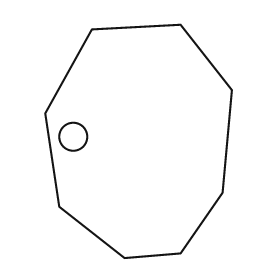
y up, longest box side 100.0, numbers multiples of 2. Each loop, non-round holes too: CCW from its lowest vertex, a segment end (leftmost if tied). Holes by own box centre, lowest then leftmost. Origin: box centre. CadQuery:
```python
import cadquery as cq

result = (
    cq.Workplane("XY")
    .moveTo(-6.0, -50.0)
    .lineTo(18.0, -48.0)
    .lineTo(36.0, -22.0)
    .lineTo(40.0, 22.0)
    .lineTo(18.0, 50.0)
    .lineTo(-20.0, 48.0)
    .lineTo(-40.0, 12.0)
    .lineTo(-34.0, -28.0)
    .close()
    .moveTo(-28.0, 2.0)
    .circle(6.0)
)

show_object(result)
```